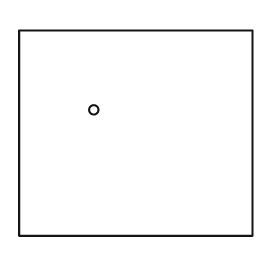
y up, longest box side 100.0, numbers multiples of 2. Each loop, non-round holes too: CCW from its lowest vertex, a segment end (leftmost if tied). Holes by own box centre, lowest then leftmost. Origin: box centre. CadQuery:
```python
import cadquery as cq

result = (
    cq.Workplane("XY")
    .moveTo(-50.0, -44.0)
    .lineTo(50.0, -44.0)
    .lineTo(50.0, 44.0)
    .lineTo(-50.0, 44.0)
    .close()
    .moveTo(-18.0, 10.0)
    .circle(2.0)
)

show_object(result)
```